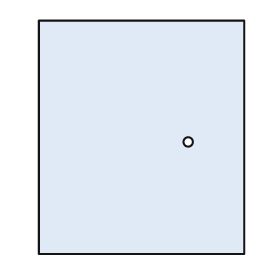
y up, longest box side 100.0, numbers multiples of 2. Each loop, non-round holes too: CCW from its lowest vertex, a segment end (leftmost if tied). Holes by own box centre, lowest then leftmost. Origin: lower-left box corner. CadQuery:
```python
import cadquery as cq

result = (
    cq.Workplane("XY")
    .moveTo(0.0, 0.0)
    .lineTo(88.0, 0.0)
    .lineTo(88.0, 100.0)
    .lineTo(0.0, 100.0)
    .close()
    .moveTo(64.0, 48.0)
    .circle(2.0)
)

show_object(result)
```